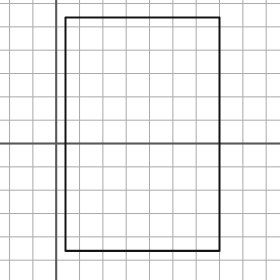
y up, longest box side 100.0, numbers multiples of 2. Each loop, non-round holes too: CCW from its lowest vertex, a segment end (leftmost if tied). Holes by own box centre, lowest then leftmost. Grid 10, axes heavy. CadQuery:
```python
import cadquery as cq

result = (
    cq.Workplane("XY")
    .moveTo(4.0, -46.0)
    .lineTo(70.0, -46.0)
    .lineTo(70.0, 54.0)
    .lineTo(4.0, 54.0)
    .close()
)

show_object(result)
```